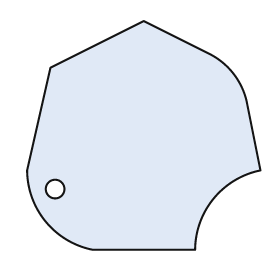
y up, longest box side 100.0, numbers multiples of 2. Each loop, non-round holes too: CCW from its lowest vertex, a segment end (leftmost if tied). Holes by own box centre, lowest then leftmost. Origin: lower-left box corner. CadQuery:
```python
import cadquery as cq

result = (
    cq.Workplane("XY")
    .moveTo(28.0, 0.0)
    .lineTo(72.0, 0.0)
    .threePointArc((80.0, 22.0), (100.0, 34.0))
    .lineTo(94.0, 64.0)
    .threePointArc((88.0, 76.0), (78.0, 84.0))
    .lineTo(50.0, 98.0)
    .lineTo(10.0, 78.0)
    .lineTo(0.0, 34.0)
    .threePointArc((8.0, 12.0), (28.0, 0.0))
    .close()
    .moveTo(12.0, 26.0)
    .circle(4.0)
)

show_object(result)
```